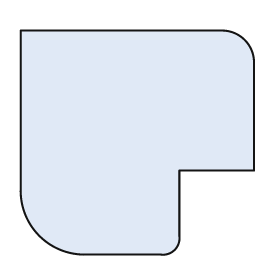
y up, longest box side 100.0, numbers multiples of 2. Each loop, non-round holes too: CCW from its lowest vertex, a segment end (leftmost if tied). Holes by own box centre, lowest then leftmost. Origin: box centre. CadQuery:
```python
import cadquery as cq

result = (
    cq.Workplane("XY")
    .moveTo(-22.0, -48.0)
    .lineTo(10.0, -48.0)
    .threePointArc((16.0, -46.0), (18.0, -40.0))
    .lineTo(18.0, -12.0)
    .lineTo(50.0, -12.0)
    .lineTo(50.0, 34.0)
    .threePointArc((46.0, 44.0), (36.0, 48.0))
    .lineTo(-50.0, 48.0)
    .lineTo(-50.0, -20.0)
    .threePointArc((-42.0, -40.0), (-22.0, -48.0))
    .close()
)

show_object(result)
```